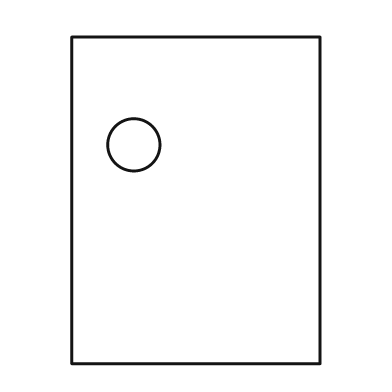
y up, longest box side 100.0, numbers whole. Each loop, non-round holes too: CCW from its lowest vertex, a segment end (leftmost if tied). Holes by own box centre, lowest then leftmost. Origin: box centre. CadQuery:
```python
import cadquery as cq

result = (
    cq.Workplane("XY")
    .moveTo(-38.0, -50.0)
    .lineTo(38.0, -50.0)
    .lineTo(38.0, 50.0)
    .lineTo(-38.0, 50.0)
    .close()
    .moveTo(-19.0, 17.0)
    .circle(8.0)
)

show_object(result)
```